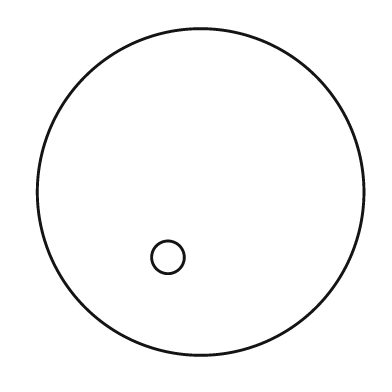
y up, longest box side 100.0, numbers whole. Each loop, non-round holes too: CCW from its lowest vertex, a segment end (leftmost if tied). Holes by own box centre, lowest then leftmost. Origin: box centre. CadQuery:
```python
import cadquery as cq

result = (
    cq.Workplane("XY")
    .moveTo(0.0, 0.0)
    .circle(50.0)
    .moveTo(-10.0, -20.0)
    .circle(5.0)
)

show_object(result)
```